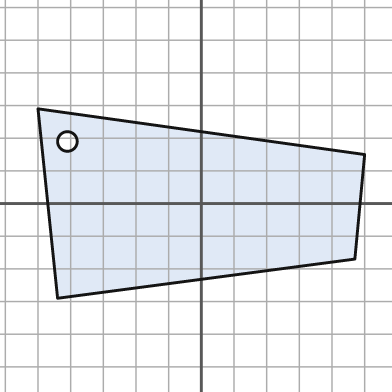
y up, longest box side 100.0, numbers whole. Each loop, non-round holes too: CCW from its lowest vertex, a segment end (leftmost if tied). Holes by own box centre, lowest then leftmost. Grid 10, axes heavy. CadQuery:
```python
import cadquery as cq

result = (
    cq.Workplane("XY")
    .moveTo(-44.0, -29.0)
    .lineTo(47.0, -17.0)
    .lineTo(50.0, 15.0)
    .lineTo(-50.0, 29.0)
    .close()
    .moveTo(-41.0, 19.0)
    .circle(3.0)
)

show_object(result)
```